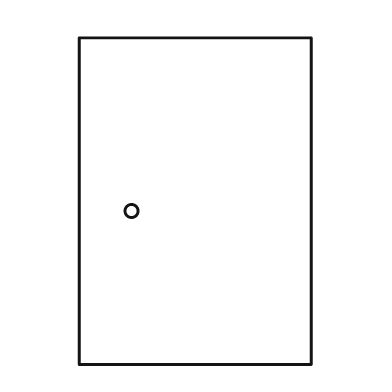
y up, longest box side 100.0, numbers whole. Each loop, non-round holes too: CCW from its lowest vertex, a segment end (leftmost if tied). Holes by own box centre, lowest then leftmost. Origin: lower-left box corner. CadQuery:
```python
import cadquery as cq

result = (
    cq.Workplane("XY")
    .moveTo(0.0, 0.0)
    .lineTo(71.0, 0.0)
    .lineTo(71.0, 100.0)
    .lineTo(0.0, 100.0)
    .close()
    .moveTo(16.0, 47.0)
    .circle(2.0)
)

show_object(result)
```